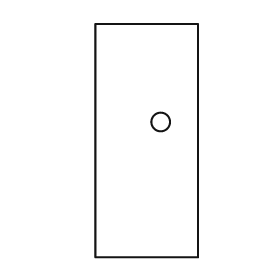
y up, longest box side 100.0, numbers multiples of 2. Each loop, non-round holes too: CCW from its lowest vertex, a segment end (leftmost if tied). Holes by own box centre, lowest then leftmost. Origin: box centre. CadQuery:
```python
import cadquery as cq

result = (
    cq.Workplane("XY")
    .moveTo(-22.0, -50.0)
    .lineTo(22.0, -50.0)
    .lineTo(22.0, 50.0)
    .lineTo(-22.0, 50.0)
    .close()
    .moveTo(6.0, 8.0)
    .circle(4.0)
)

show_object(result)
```